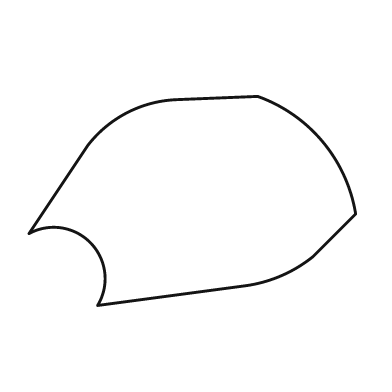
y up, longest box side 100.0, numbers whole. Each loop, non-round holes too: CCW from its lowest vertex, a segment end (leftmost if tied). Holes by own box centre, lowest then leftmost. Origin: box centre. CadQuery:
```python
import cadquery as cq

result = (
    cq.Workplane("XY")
    .moveTo(-29.0, -32.0)
    .lineTo(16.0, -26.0)
    .threePointArc((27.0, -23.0), (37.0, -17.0))
    .lineTo(50.0, -4.0)
    .threePointArc((40.0, 18.0), (20.0, 32.0))
    .lineTo(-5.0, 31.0)
    .threePointArc((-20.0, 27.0), (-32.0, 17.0))
    .lineTo(-50.0, -10.0)
    .threePointArc((-31.0, -13.0), (-29.0, -32.0))
    .close()
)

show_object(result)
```